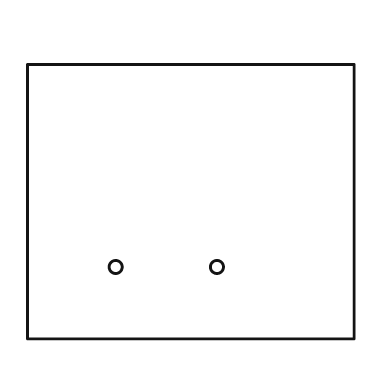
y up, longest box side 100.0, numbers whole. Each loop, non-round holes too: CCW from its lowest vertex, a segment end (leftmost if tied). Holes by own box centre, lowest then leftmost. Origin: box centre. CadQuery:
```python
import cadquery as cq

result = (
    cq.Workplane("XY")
    .moveTo(-50.0, -42.0)
    .lineTo(50.0, -42.0)
    .lineTo(50.0, 42.0)
    .lineTo(-50.0, 42.0)
    .close()
    .moveTo(-23.0, -20.0)
    .circle(2.0)
    .moveTo(8.0, -20.0)
    .circle(2.0)
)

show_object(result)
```